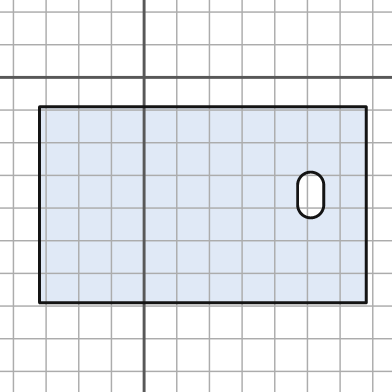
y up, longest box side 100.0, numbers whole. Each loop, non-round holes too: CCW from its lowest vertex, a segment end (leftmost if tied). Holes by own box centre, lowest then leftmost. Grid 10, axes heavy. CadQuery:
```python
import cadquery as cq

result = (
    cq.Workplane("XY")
    .moveTo(-32.0, -69.0)
    .lineTo(68.0, -69.0)
    .lineTo(68.0, -9.0)
    .lineTo(-32.0, -9.0)
    .close()
    .moveTo(47.0, -39.0)
    .threePointArc((51.0, -43.0), (55.0, -39.0))
    .lineTo(55.0, -33.0)
    .threePointArc((51.0, -29.0), (47.0, -33.0))
    .close()
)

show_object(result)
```